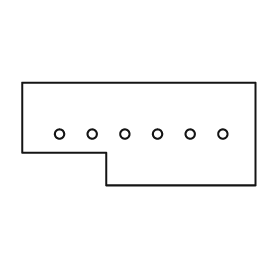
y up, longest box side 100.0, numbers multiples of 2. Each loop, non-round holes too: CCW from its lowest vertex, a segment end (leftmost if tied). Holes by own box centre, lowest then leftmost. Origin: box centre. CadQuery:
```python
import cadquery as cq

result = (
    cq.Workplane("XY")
    .moveTo(-14.0, -22.0)
    .lineTo(50.0, -22.0)
    .lineTo(50.0, 22.0)
    .lineTo(-50.0, 22.0)
    .lineTo(-50.0, -8.0)
    .lineTo(-14.0, -8.0)
    .close()
    .moveTo(-34.0, 0.0)
    .circle(2.0)
    .moveTo(-20.0, 0.0)
    .circle(2.0)
    .moveTo(-6.0, 0.0)
    .circle(2.0)
    .moveTo(8.0, 0.0)
    .circle(2.0)
    .moveTo(22.0, 0.0)
    .circle(2.0)
    .moveTo(36.0, 0.0)
    .circle(2.0)
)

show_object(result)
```